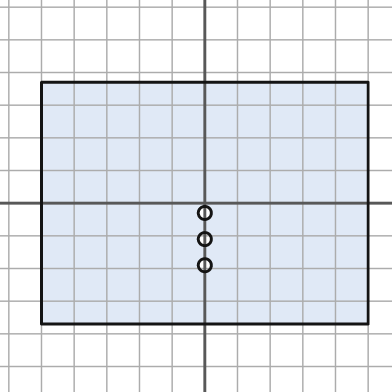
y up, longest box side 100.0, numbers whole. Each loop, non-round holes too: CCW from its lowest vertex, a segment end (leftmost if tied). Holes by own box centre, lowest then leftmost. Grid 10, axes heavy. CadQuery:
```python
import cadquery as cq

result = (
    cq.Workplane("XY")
    .moveTo(-50.0, -37.0)
    .lineTo(50.0, -37.0)
    .lineTo(50.0, 37.0)
    .lineTo(-50.0, 37.0)
    .close()
    .moveTo(0.0, -19.0)
    .circle(2.0)
    .moveTo(0.0, -11.0)
    .circle(2.0)
    .moveTo(0.0, -3.0)
    .circle(2.0)
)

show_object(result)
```